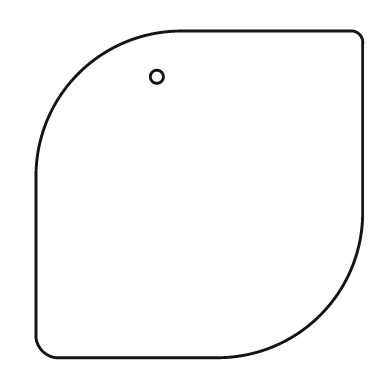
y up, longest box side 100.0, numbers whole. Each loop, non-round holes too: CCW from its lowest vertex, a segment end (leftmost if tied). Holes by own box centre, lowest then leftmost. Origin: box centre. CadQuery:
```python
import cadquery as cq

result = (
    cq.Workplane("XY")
    .moveTo(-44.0, -50.0)
    .lineTo(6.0, -50.0)
    .threePointArc((37.0, -37.0), (50.0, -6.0))
    .lineTo(50.0, 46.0)
    .threePointArc((49.0, 49.0), (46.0, 50.0))
    .lineTo(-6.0, 50.0)
    .threePointArc((-37.0, 37.0), (-50.0, 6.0))
    .lineTo(-50.0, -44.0)
    .threePointArc((-48.0, -48.0), (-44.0, -50.0))
    .close()
    .moveTo(-13.0, 36.0)
    .circle(2.0)
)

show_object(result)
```